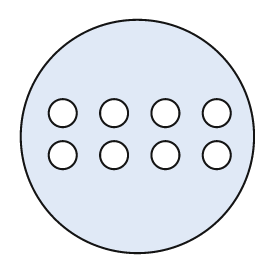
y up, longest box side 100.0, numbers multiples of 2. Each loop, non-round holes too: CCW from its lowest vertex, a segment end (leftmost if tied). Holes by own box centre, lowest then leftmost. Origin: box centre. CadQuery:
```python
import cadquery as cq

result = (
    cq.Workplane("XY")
    .moveTo(0.0, 0.0)
    .circle(50.0)
    .moveTo(-32.0, -8.0)
    .circle(6.0)
    .moveTo(-10.0, -8.0)
    .circle(6.0)
    .moveTo(12.0, -8.0)
    .circle(6.0)
    .moveTo(34.0, -8.0)
    .circle(6.0)
    .moveTo(-32.0, 10.0)
    .circle(6.0)
    .moveTo(-10.0, 10.0)
    .circle(6.0)
    .moveTo(12.0, 10.0)
    .circle(6.0)
    .moveTo(34.0, 10.0)
    .circle(6.0)
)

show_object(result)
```